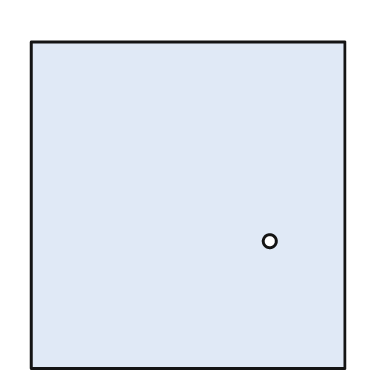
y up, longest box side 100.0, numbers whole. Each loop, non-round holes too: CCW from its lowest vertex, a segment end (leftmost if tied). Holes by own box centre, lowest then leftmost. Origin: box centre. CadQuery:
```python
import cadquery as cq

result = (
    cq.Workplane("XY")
    .moveTo(-48.0, -50.0)
    .lineTo(48.0, -50.0)
    .lineTo(48.0, 50.0)
    .lineTo(-48.0, 50.0)
    .close()
    .moveTo(25.0, -11.0)
    .circle(2.0)
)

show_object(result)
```